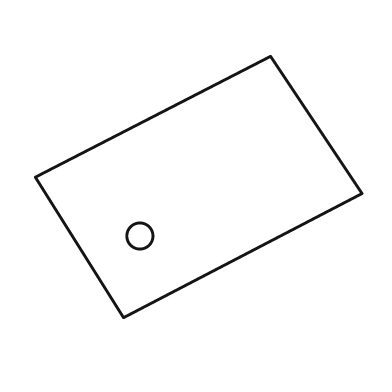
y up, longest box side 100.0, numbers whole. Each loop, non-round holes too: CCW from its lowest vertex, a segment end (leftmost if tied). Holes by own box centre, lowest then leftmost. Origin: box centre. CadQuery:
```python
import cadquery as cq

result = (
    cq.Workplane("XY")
    .moveTo(-23.0, -40.0)
    .lineTo(50.0, -2.0)
    .lineTo(22.0, 40.0)
    .lineTo(-50.0, 3.0)
    .close()
    .moveTo(-18.0, -15.0)
    .circle(4.0)
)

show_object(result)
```